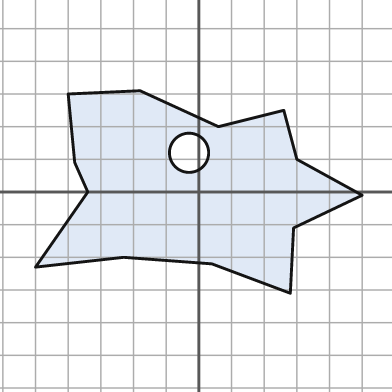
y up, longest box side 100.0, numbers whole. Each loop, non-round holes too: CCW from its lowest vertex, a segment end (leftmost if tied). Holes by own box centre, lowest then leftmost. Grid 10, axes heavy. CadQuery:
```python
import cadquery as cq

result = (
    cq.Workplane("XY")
    .moveTo(28.0, -31.0)
    .lineTo(29.0, -11.0)
    .lineTo(50.0, -1.0)
    .lineTo(30.0, 10.0)
    .lineTo(26.0, 25.0)
    .lineTo(6.0, 20.0)
    .lineTo(-18.0, 31.0)
    .lineTo(-40.0, 30.0)
    .lineTo(-38.0, 9.0)
    .lineTo(-34.0, 0.0)
    .lineTo(-50.0, -23.0)
    .lineTo(-23.0, -20.0)
    .lineTo(4.0, -22.0)
    .close()
    .moveTo(-3.0, 12.0)
    .circle(6.0)
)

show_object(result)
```